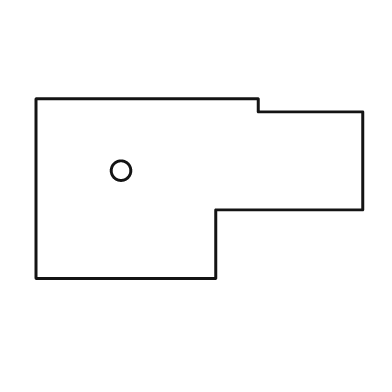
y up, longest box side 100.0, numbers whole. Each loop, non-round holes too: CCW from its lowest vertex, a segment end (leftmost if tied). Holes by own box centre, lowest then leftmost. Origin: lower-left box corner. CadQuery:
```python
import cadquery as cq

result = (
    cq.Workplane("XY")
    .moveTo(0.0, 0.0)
    .lineTo(55.0, 0.0)
    .lineTo(55.0, 21.0)
    .lineTo(100.0, 21.0)
    .lineTo(100.0, 51.0)
    .lineTo(68.0, 51.0)
    .lineTo(68.0, 55.0)
    .lineTo(0.0, 55.0)
    .close()
    .moveTo(26.0, 33.0)
    .circle(3.0)
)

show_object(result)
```